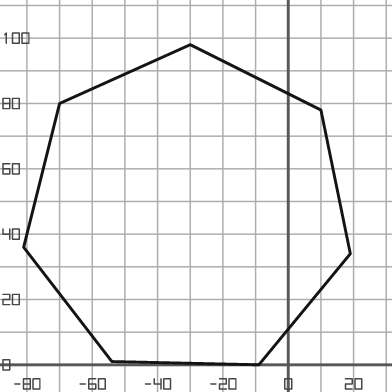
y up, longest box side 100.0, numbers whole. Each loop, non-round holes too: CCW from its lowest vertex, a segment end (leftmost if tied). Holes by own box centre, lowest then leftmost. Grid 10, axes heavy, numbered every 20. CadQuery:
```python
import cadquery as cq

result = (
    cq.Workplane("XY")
    .moveTo(-9.0, 0.0)
    .lineTo(19.0, 34.0)
    .lineTo(10.0, 78.0)
    .lineTo(-30.0, 98.0)
    .lineTo(-70.0, 80.0)
    .lineTo(-81.0, 36.0)
    .lineTo(-54.0, 1.0)
    .close()
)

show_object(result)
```